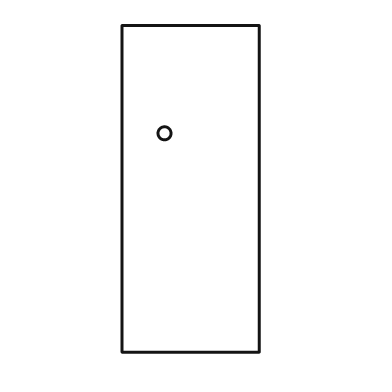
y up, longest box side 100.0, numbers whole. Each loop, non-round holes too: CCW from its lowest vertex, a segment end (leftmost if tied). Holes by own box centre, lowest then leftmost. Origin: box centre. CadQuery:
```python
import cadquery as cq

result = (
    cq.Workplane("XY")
    .moveTo(-21.0, -50.0)
    .lineTo(21.0, -50.0)
    .lineTo(21.0, 50.0)
    .lineTo(-21.0, 50.0)
    .close()
    .moveTo(-8.0, 17.0)
    .circle(2.0)
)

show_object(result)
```